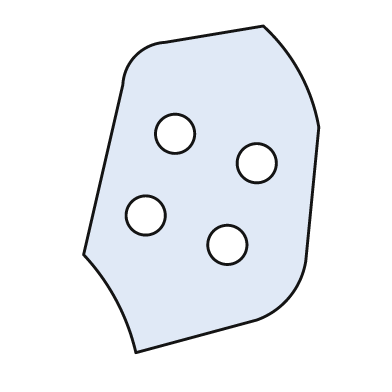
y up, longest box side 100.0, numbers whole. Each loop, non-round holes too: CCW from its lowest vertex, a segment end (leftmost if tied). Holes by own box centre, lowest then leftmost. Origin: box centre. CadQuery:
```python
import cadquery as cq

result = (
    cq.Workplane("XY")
    .moveTo(-20.0, -50.0)
    .lineTo(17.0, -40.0)
    .threePointArc((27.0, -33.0), (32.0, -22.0))
    .lineTo(36.0, 19.0)
    .threePointArc((30.0, 36.0), (19.0, 50.0))
    .lineTo(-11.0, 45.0)
    .threePointArc((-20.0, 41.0), (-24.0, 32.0))
    .lineTo(-36.0, -20.0)
    .threePointArc((-26.0, -34.0), (-20.0, -50.0))
    .close()
    .moveTo(8.0, -17.0)
    .circle(6.0)
    .moveTo(-17.0, -8.0)
    .circle(6.0)
    .moveTo(17.0, 8.0)
    .circle(6.0)
    .moveTo(-8.0, 17.0)
    .circle(6.0)
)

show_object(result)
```